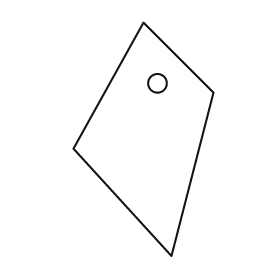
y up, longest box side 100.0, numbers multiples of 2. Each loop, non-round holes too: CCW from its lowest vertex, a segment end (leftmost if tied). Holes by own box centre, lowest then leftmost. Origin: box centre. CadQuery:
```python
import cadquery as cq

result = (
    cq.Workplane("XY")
    .moveTo(12.0, -50.0)
    .lineTo(30.0, 20.0)
    .lineTo(0.0, 50.0)
    .lineTo(-30.0, -4.0)
    .close()
    .moveTo(6.0, 24.0)
    .circle(4.0)
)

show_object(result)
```